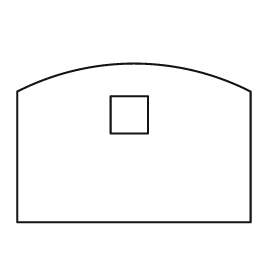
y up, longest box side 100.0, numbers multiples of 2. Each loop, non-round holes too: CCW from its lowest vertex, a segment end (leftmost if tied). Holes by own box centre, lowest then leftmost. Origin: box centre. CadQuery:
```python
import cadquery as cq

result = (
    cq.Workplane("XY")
    .moveTo(-50.0, -34.0)
    .lineTo(50.0, -34.0)
    .lineTo(50.0, 22.0)
    .threePointArc((0.0, 34.0), (-50.0, 22.0))
    .close()
    .moveTo(-10.0, 4.0)
    .lineTo(6.0, 4.0)
    .lineTo(6.0, 20.0)
    .lineTo(-10.0, 20.0)
    .close()
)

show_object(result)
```